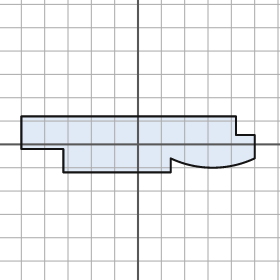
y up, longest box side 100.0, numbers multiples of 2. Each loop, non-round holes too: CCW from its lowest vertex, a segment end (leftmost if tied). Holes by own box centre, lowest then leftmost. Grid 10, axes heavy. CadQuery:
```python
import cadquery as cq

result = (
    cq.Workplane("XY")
    .moveTo(-32.0, -12.0)
    .lineTo(14.0, -12.0)
    .lineTo(14.0, -6.0)
    .threePointArc((32.0, -10.0), (50.0, -6.0))
    .lineTo(50.0, 4.0)
    .lineTo(42.0, 4.0)
    .lineTo(42.0, 12.0)
    .lineTo(-50.0, 12.0)
    .lineTo(-50.0, -2.0)
    .lineTo(-32.0, -2.0)
    .close()
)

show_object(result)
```